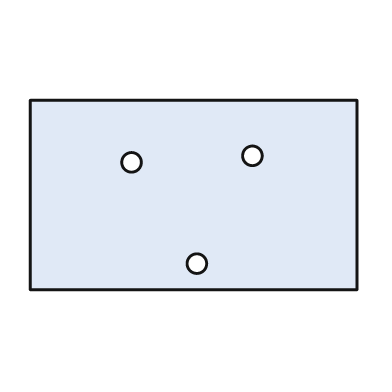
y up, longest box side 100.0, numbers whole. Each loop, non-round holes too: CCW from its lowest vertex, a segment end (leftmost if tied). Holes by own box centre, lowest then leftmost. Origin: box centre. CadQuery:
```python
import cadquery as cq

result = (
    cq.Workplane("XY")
    .moveTo(-50.0, -29.0)
    .lineTo(50.0, -29.0)
    .lineTo(50.0, 29.0)
    .lineTo(-50.0, 29.0)
    .close()
    .moveTo(1.0, -21.0)
    .circle(3.0)
    .moveTo(-19.0, 10.0)
    .circle(3.0)
    .moveTo(18.0, 12.0)
    .circle(3.0)
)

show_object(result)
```